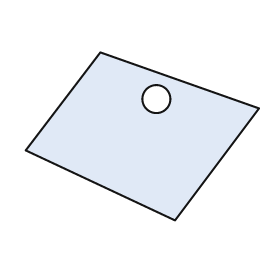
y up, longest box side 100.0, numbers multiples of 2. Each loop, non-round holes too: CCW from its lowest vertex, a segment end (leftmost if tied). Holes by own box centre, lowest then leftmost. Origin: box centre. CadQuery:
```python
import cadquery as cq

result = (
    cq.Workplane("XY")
    .moveTo(14.0, -36.0)
    .lineTo(50.0, 12.0)
    .lineTo(-18.0, 36.0)
    .lineTo(-50.0, -6.0)
    .close()
    .moveTo(6.0, 16.0)
    .circle(6.0)
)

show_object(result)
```